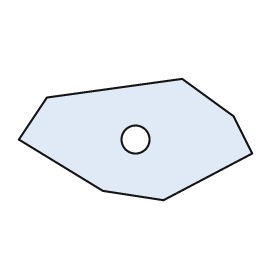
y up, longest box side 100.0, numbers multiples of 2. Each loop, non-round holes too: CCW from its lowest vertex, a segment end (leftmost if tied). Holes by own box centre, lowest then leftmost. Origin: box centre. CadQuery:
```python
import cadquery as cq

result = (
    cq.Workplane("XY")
    .moveTo(12.0, -26.0)
    .lineTo(50.0, -6.0)
    .lineTo(42.0, 10.0)
    .lineTo(20.0, 26.0)
    .lineTo(-38.0, 18.0)
    .lineTo(-50.0, 0.0)
    .lineTo(-14.0, -22.0)
    .close()
    .moveTo(0.0, 0.0)
    .circle(6.0)
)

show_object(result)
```